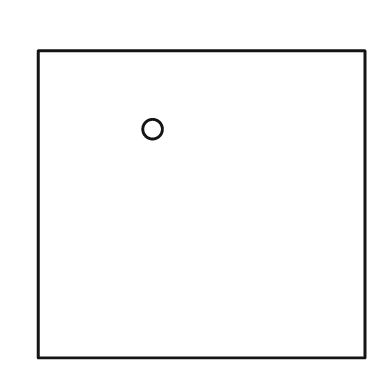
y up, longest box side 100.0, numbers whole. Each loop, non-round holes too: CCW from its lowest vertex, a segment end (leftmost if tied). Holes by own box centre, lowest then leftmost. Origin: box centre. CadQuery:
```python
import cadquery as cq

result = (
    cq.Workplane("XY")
    .moveTo(-50.0, -47.0)
    .lineTo(50.0, -47.0)
    .lineTo(50.0, 47.0)
    .lineTo(-50.0, 47.0)
    .close()
    .moveTo(-15.0, 23.0)
    .circle(3.0)
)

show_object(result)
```